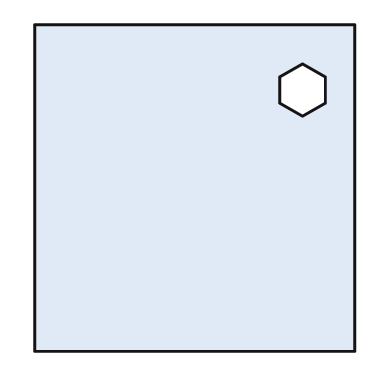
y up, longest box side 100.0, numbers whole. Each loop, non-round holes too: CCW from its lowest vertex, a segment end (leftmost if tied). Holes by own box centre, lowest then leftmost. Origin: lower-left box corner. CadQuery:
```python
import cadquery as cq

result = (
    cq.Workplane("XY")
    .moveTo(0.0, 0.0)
    .lineTo(98.0, 0.0)
    .lineTo(98.0, 100.0)
    .lineTo(0.0, 100.0)
    .close()
    .moveTo(82.0, 72.0)
    .lineTo(89.0, 76.0)
    .lineTo(89.0, 84.0)
    .lineTo(82.0, 88.0)
    .lineTo(75.0, 84.0)
    .lineTo(75.0, 76.0)
    .close()
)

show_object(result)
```